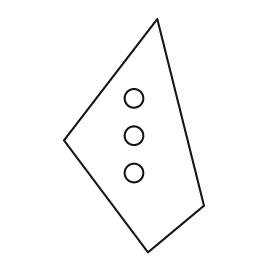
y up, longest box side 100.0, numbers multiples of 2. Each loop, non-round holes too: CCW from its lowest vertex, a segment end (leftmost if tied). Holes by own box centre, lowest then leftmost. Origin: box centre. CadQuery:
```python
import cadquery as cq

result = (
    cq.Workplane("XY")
    .moveTo(6.0, -50.0)
    .lineTo(30.0, -30.0)
    .lineTo(10.0, 50.0)
    .lineTo(-30.0, -2.0)
    .close()
    .moveTo(0.0, -16.0)
    .circle(4.0)
    .moveTo(0.0, 0.0)
    .circle(4.0)
    .moveTo(0.0, 16.0)
    .circle(4.0)
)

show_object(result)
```